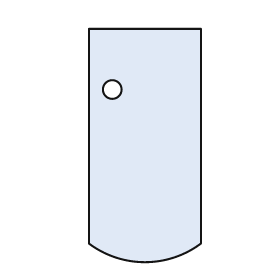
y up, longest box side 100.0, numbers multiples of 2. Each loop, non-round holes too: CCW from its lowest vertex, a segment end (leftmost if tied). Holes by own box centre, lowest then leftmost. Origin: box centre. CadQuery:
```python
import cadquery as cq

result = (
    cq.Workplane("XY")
    .moveTo(-24.0, -42.0)
    .threePointArc((0.0, -50.0), (24.0, -42.0))
    .lineTo(24.0, 50.0)
    .lineTo(-24.0, 50.0)
    .close()
    .moveTo(-14.0, 24.0)
    .circle(4.0)
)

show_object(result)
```